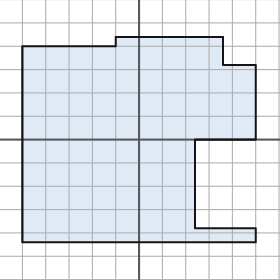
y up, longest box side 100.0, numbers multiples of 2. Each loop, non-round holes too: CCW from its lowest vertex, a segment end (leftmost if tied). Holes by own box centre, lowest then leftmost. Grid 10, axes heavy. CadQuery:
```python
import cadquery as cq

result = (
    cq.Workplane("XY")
    .moveTo(-50.0, -44.0)
    .lineTo(50.0, -44.0)
    .lineTo(50.0, -38.0)
    .lineTo(24.0, -38.0)
    .lineTo(24.0, 0.0)
    .lineTo(50.0, 0.0)
    .lineTo(50.0, 32.0)
    .lineTo(36.0, 32.0)
    .lineTo(36.0, 44.0)
    .lineTo(-10.0, 44.0)
    .lineTo(-10.0, 40.0)
    .lineTo(-50.0, 40.0)
    .close()
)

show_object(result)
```